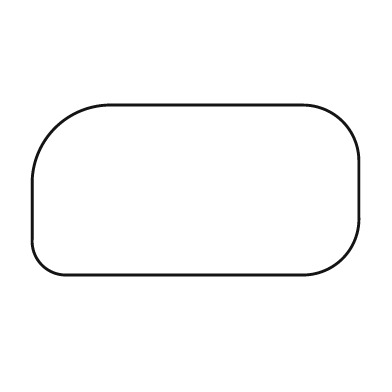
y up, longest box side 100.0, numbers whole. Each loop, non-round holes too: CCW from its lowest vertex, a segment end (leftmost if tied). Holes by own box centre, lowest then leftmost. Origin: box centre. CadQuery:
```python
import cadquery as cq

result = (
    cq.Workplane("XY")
    .moveTo(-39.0, -26.0)
    .lineTo(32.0, -26.0)
    .threePointArc((45.0, -21.0), (50.0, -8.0))
    .lineTo(50.0, 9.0)
    .threePointArc((45.0, 21.0), (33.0, 26.0))
    .lineTo(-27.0, 26.0)
    .threePointArc((-43.0, 19.0), (-50.0, 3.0))
    .lineTo(-50.0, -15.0)
    .threePointArc((-47.0, -23.0), (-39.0, -26.0))
    .close()
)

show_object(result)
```